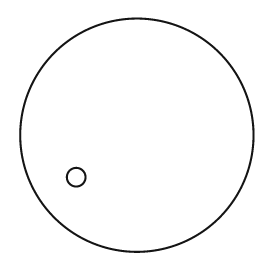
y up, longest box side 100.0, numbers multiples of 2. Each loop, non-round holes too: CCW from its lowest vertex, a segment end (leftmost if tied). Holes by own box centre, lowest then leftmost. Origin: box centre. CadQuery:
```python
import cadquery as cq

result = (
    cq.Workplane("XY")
    .moveTo(0.0, 0.0)
    .circle(50.0)
    .moveTo(-26.0, -18.0)
    .circle(4.0)
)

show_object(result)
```